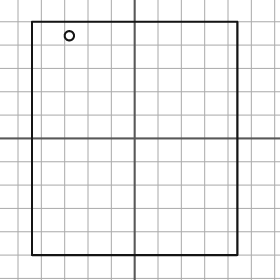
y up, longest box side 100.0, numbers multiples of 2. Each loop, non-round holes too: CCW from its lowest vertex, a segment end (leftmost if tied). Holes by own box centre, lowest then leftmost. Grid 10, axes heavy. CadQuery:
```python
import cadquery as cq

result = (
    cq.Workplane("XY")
    .moveTo(-44.0, -50.0)
    .lineTo(44.0, -50.0)
    .lineTo(44.0, 50.0)
    .lineTo(-44.0, 50.0)
    .close()
    .moveTo(-28.0, 44.0)
    .circle(2.0)
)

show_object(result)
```